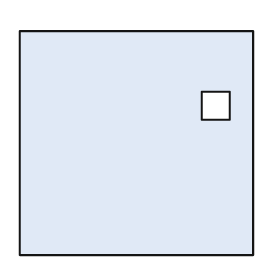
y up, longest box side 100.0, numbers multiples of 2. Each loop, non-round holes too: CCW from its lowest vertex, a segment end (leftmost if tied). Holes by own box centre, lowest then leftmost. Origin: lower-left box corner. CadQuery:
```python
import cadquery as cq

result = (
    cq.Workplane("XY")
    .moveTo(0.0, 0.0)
    .lineTo(100.0, 0.0)
    .lineTo(100.0, 96.0)
    .lineTo(0.0, 96.0)
    .close()
    .moveTo(78.0, 58.0)
    .lineTo(90.0, 58.0)
    .lineTo(90.0, 70.0)
    .lineTo(78.0, 70.0)
    .close()
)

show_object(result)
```